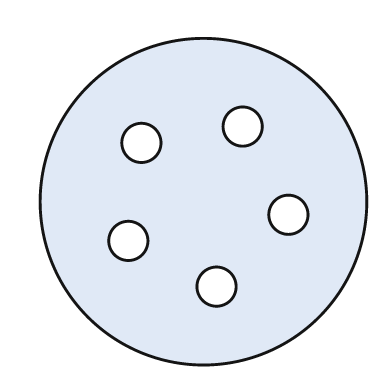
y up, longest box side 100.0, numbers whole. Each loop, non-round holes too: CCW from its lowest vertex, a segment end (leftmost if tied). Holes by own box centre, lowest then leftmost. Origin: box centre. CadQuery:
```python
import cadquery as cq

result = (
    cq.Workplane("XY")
    .moveTo(0.0, 0.0)
    .circle(50.0)
    .moveTo(4.0, -26.0)
    .circle(6.0)
    .moveTo(-23.0, -12.0)
    .circle(6.0)
    .moveTo(26.0, -4.0)
    .circle(6.0)
    .moveTo(-19.0, 18.0)
    .circle(6.0)
    .moveTo(12.0, 23.0)
    .circle(6.0)
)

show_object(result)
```